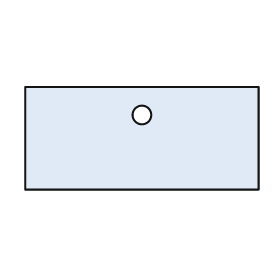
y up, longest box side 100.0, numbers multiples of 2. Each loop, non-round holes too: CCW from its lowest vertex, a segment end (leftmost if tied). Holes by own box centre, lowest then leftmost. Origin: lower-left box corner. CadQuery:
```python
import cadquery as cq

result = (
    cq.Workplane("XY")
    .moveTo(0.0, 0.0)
    .lineTo(100.0, 0.0)
    .lineTo(100.0, 44.0)
    .lineTo(0.0, 44.0)
    .close()
    .moveTo(50.0, 32.0)
    .circle(4.0)
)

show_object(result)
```